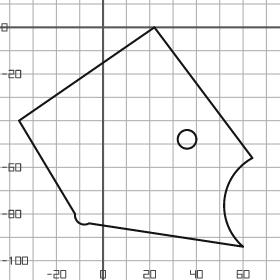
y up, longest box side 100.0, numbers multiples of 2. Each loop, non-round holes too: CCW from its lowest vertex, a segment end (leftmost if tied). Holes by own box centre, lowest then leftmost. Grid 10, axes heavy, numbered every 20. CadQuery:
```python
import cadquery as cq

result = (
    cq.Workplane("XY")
    .moveTo(60.0, -94.0)
    .threePointArc((52.0, -74.0), (64.0, -56.0))
    .lineTo(22.0, 0.0)
    .lineTo(-36.0, -40.0)
    .lineTo(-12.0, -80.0)
    .threePointArc((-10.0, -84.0), (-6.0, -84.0))
    .close()
    .moveTo(36.0, -48.0)
    .circle(4.0)
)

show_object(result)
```